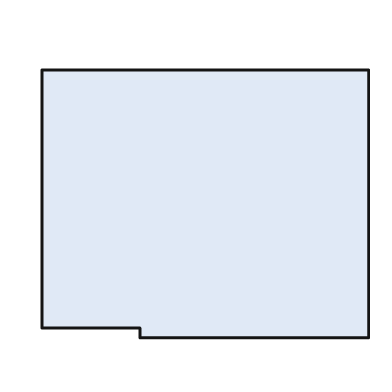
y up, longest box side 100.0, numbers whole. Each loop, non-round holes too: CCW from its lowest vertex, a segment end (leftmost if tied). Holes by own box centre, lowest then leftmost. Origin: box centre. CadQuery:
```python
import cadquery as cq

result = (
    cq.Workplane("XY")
    .moveTo(-20.0, -41.0)
    .lineTo(50.0, -41.0)
    .lineTo(50.0, 41.0)
    .lineTo(-50.0, 41.0)
    .lineTo(-50.0, -38.0)
    .lineTo(-20.0, -38.0)
    .close()
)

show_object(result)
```